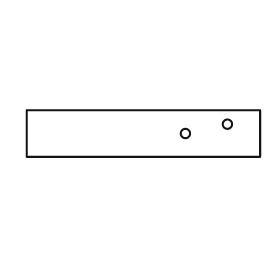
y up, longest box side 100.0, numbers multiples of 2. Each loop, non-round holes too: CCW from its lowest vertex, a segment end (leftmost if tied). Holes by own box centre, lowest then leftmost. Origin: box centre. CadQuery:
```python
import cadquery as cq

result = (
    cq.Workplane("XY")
    .moveTo(-50.0, -10.0)
    .lineTo(50.0, -10.0)
    .lineTo(50.0, 10.0)
    .lineTo(-50.0, 10.0)
    .close()
    .moveTo(18.0, 0.0)
    .circle(2.0)
    .moveTo(36.0, 4.0)
    .circle(2.0)
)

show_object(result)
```